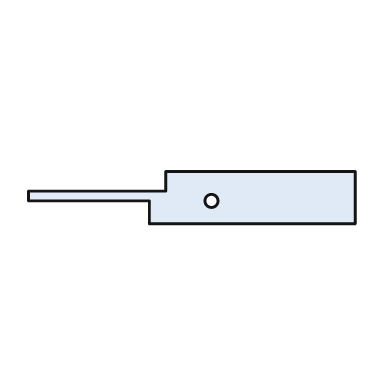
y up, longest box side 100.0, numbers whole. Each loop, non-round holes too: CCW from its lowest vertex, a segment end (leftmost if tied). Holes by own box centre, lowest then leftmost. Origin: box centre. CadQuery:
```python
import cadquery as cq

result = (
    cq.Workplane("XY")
    .moveTo(-13.0, -8.0)
    .lineTo(50.0, -8.0)
    .lineTo(50.0, 8.0)
    .lineTo(-8.0, 8.0)
    .lineTo(-8.0, 2.0)
    .lineTo(-50.0, 2.0)
    .lineTo(-50.0, -1.0)
    .lineTo(-13.0, -1.0)
    .close()
    .moveTo(6.0, -1.0)
    .circle(2.0)
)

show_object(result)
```